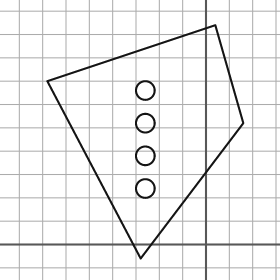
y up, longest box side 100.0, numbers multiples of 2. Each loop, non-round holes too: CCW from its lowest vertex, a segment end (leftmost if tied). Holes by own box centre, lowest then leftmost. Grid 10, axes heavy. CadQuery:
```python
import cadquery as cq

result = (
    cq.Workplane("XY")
    .moveTo(-28.0, -6.0)
    .lineTo(16.0, 52.0)
    .lineTo(4.0, 94.0)
    .lineTo(-68.0, 70.0)
    .close()
    .moveTo(-26.0, 24.0)
    .circle(4.0)
    .moveTo(-26.0, 38.0)
    .circle(4.0)
    .moveTo(-26.0, 52.0)
    .circle(4.0)
    .moveTo(-26.0, 66.0)
    .circle(4.0)
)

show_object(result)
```